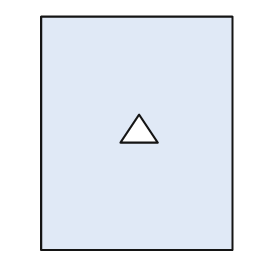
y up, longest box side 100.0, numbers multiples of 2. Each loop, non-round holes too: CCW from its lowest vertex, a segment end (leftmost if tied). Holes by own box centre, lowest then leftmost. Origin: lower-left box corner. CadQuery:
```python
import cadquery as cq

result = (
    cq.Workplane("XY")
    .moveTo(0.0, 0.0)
    .lineTo(82.0, 0.0)
    .lineTo(82.0, 100.0)
    .lineTo(0.0, 100.0)
    .close()
    .moveTo(34.0, 46.0)
    .lineTo(50.0, 46.0)
    .lineTo(42.0, 58.0)
    .close()
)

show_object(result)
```